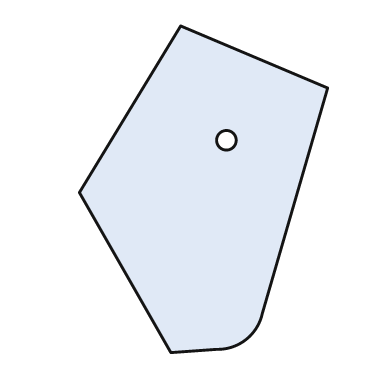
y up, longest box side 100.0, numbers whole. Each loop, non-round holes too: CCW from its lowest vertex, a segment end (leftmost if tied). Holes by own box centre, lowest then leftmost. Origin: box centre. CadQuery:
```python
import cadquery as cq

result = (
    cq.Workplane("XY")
    .moveTo(-10.0, -50.0)
    .lineTo(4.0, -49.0)
    .threePointArc((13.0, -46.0), (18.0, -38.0))
    .lineTo(38.0, 31.0)
    .lineTo(-7.0, 50.0)
    .lineTo(-38.0, -1.0)
    .close()
    .moveTo(7.0, 15.0)
    .circle(3.0)
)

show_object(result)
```